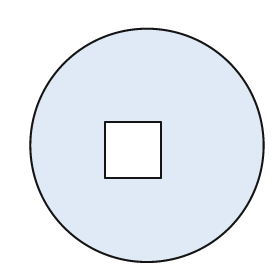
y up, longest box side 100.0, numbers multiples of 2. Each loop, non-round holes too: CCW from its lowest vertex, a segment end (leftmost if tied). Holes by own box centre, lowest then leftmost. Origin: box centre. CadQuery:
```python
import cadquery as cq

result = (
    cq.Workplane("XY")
    .moveTo(0.0, 0.0)
    .circle(50.0)
    .moveTo(-18.0, -14.0)
    .lineTo(6.0, -14.0)
    .lineTo(6.0, 10.0)
    .lineTo(-18.0, 10.0)
    .close()
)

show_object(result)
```